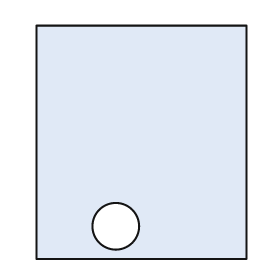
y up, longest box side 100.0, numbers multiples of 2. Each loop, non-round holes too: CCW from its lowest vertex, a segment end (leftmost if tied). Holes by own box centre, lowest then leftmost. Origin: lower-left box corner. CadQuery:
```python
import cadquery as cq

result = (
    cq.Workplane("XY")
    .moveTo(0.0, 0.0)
    .lineTo(90.0, 0.0)
    .lineTo(90.0, 100.0)
    .lineTo(0.0, 100.0)
    .close()
    .moveTo(34.0, 14.0)
    .circle(10.0)
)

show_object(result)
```